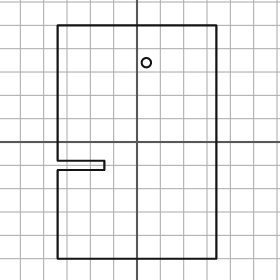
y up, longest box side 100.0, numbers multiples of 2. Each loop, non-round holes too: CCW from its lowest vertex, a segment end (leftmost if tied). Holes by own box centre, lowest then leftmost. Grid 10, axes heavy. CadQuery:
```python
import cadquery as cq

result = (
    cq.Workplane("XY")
    .moveTo(-34.0, -50.0)
    .lineTo(34.0, -50.0)
    .lineTo(34.0, 50.0)
    .lineTo(-34.0, 50.0)
    .lineTo(-34.0, -8.0)
    .lineTo(-14.0, -8.0)
    .lineTo(-14.0, -12.0)
    .lineTo(-34.0, -12.0)
    .close()
    .moveTo(4.0, 34.0)
    .circle(2.0)
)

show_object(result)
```